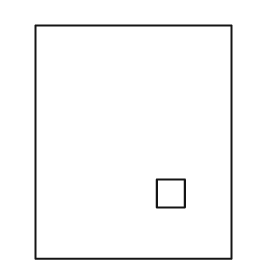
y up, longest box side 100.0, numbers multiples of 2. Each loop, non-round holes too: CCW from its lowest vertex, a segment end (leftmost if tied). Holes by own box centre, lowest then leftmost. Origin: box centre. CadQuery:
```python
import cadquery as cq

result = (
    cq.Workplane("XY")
    .moveTo(-42.0, -50.0)
    .lineTo(42.0, -50.0)
    .lineTo(42.0, 50.0)
    .lineTo(-42.0, 50.0)
    .close()
    .moveTo(10.0, -28.0)
    .lineTo(22.0, -28.0)
    .lineTo(22.0, -16.0)
    .lineTo(10.0, -16.0)
    .close()
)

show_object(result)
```